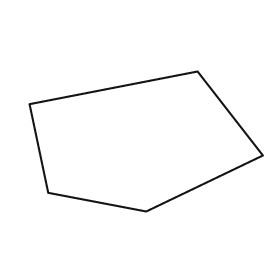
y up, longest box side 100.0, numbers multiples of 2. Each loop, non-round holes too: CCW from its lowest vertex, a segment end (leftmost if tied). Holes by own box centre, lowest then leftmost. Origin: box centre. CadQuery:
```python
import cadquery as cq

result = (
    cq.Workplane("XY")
    .moveTo(0.0, -30.0)
    .lineTo(50.0, -6.0)
    .lineTo(22.0, 30.0)
    .lineTo(-50.0, 16.0)
    .lineTo(-42.0, -22.0)
    .close()
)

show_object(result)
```